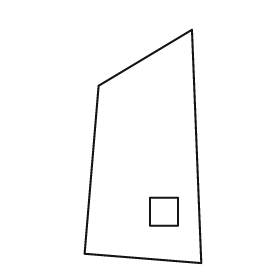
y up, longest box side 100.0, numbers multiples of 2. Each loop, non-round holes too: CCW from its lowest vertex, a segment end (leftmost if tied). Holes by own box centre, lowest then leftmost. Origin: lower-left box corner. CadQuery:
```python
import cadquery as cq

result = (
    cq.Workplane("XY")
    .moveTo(50.0, 0.0)
    .lineTo(46.0, 100.0)
    .lineTo(6.0, 76.0)
    .lineTo(0.0, 4.0)
    .close()
    .moveTo(28.0, 16.0)
    .lineTo(40.0, 16.0)
    .lineTo(40.0, 28.0)
    .lineTo(28.0, 28.0)
    .close()
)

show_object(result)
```